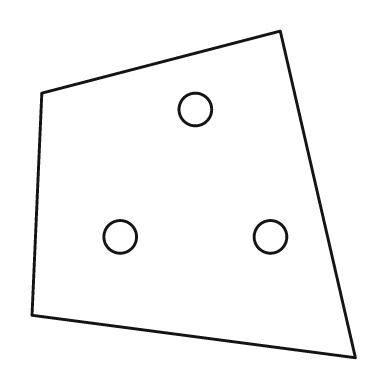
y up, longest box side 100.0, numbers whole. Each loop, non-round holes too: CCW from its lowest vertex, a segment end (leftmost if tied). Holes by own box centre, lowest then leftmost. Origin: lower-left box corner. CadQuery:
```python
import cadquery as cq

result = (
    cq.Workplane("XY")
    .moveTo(99.0, 0.0)
    .lineTo(76.0, 100.0)
    .lineTo(3.0, 81.0)
    .lineTo(0.0, 13.0)
    .close()
    .moveTo(27.0, 37.0)
    .circle(5.0)
    .moveTo(73.0, 37.0)
    .circle(5.0)
    .moveTo(50.0, 76.0)
    .circle(5.0)
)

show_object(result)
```